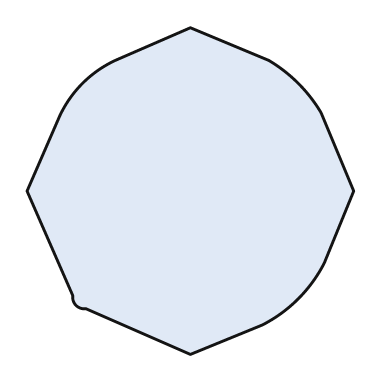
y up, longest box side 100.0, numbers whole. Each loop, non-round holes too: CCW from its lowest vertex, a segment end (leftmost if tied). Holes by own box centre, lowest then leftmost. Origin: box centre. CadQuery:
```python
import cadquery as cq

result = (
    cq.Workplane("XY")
    .moveTo(0.0, -50.0)
    .lineTo(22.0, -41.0)
    .threePointArc((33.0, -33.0), (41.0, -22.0))
    .lineTo(50.0, 0.0)
    .lineTo(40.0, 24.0)
    .threePointArc((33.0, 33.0), (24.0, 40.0))
    .lineTo(0.0, 50.0)
    .lineTo(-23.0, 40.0)
    .threePointArc((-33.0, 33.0), (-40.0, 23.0))
    .lineTo(-50.0, 0.0)
    .lineTo(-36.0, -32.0)
    .threePointArc((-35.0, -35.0), (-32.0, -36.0))
    .close()
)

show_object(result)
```